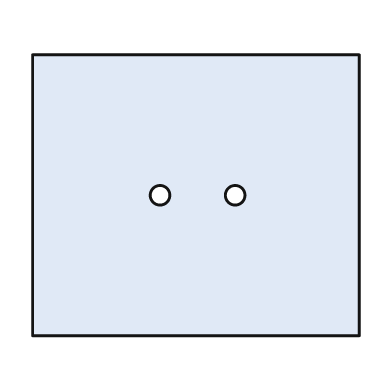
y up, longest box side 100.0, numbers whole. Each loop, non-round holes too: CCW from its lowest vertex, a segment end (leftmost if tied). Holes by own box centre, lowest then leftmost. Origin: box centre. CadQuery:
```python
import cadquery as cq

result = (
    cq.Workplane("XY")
    .moveTo(-50.0, -43.0)
    .lineTo(50.0, -43.0)
    .lineTo(50.0, 43.0)
    .lineTo(-50.0, 43.0)
    .close()
    .moveTo(-11.0, 0.0)
    .circle(3.0)
    .moveTo(12.0, 0.0)
    .circle(3.0)
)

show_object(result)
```